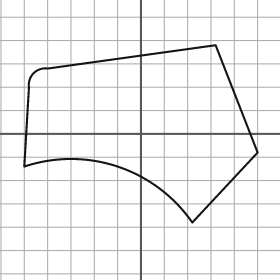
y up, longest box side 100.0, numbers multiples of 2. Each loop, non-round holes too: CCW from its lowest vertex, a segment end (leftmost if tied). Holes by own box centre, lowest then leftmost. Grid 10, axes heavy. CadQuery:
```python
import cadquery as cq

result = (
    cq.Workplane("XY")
    .moveTo(22.0, -38.0)
    .lineTo(50.0, -8.0)
    .lineTo(32.0, 38.0)
    .lineTo(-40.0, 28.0)
    .threePointArc((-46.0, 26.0), (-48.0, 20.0))
    .lineTo(-50.0, -14.0)
    .threePointArc((-10.0, -14.0), (22.0, -38.0))
    .close()
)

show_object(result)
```